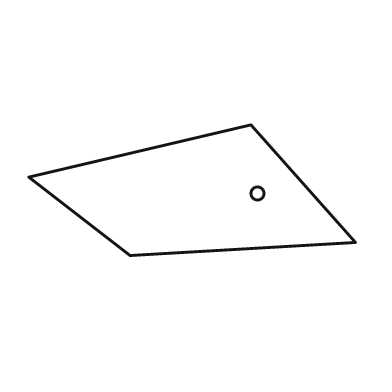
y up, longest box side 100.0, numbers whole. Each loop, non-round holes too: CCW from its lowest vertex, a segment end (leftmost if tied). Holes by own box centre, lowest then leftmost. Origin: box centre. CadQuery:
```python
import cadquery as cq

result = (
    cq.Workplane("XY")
    .moveTo(-19.0, -20.0)
    .lineTo(50.0, -16.0)
    .lineTo(18.0, 20.0)
    .lineTo(-50.0, 4.0)
    .close()
    .moveTo(20.0, -1.0)
    .circle(2.0)
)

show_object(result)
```